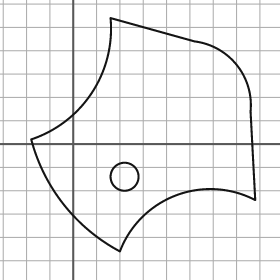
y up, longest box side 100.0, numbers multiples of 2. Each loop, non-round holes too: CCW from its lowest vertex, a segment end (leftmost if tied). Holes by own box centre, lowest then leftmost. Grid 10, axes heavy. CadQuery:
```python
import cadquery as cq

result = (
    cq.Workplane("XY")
    .moveTo(20.0, -46.0)
    .threePointArc((44.0, -22.0), (78.0, -24.0))
    .lineTo(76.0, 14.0)
    .threePointArc((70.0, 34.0), (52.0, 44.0))
    .lineTo(16.0, 54.0)
    .threePointArc((8.0, 22.0), (-18.0, 2.0))
    .threePointArc((-4.0, -26.0), (20.0, -46.0))
    .close()
    .moveTo(22.0, -14.0)
    .circle(6.0)
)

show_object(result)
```